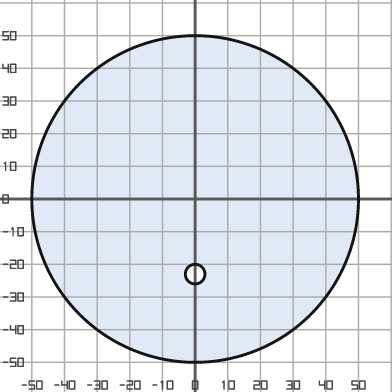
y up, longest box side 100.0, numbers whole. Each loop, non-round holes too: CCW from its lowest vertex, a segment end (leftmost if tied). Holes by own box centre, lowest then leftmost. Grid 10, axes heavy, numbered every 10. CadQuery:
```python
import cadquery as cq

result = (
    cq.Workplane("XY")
    .moveTo(0.0, 0.0)
    .circle(50.0)
    .moveTo(0.0, -23.0)
    .circle(3.0)
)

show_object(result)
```